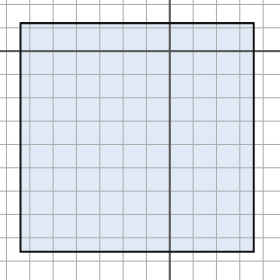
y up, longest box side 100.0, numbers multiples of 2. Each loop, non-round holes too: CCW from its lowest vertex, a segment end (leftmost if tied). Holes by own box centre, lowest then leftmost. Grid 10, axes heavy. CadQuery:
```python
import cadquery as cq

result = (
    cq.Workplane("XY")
    .moveTo(-64.0, -86.0)
    .lineTo(36.0, -86.0)
    .lineTo(36.0, 12.0)
    .lineTo(-64.0, 12.0)
    .close()
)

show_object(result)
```